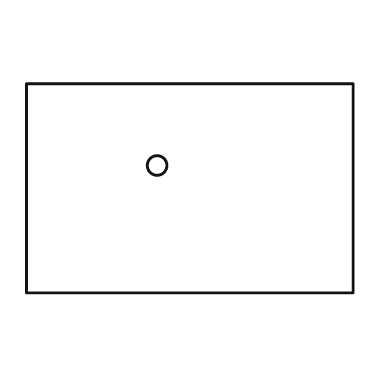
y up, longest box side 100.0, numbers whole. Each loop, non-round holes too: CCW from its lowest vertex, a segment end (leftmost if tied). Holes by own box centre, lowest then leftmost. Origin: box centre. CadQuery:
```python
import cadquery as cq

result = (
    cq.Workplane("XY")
    .moveTo(-50.0, -32.0)
    .lineTo(50.0, -32.0)
    .lineTo(50.0, 32.0)
    .lineTo(-50.0, 32.0)
    .close()
    .moveTo(-10.0, 7.0)
    .circle(3.0)
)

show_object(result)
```